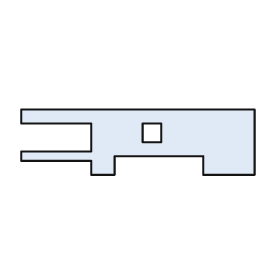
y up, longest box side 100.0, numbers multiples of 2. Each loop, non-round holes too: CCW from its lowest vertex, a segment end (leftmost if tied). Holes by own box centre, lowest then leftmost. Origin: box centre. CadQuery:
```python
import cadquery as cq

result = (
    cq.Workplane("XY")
    .moveTo(-20.0, -14.0)
    .lineTo(-10.0, -14.0)
    .lineTo(-10.0, -6.0)
    .lineTo(28.0, -6.0)
    .lineTo(28.0, -14.0)
    .lineTo(50.0, -14.0)
    .lineTo(50.0, 14.0)
    .lineTo(-50.0, 14.0)
    .lineTo(-50.0, 8.0)
    .lineTo(-20.0, 8.0)
    .lineTo(-20.0, -4.0)
    .lineTo(-50.0, -4.0)
    .lineTo(-50.0, -8.0)
    .lineTo(-20.0, -8.0)
    .close()
    .moveTo(2.0, 0.0)
    .lineTo(10.0, 0.0)
    .lineTo(10.0, 8.0)
    .lineTo(2.0, 8.0)
    .close()
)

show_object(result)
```